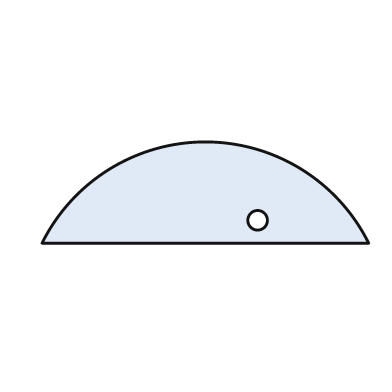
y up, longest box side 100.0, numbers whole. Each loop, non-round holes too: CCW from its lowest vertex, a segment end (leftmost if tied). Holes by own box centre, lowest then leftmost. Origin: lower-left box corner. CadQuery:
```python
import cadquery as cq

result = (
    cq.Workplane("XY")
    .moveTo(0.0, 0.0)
    .lineTo(100.0, 0.0)
    .threePointArc((50.0, 31.0), (0.0, 0.0))
    .close()
    .moveTo(66.0, 7.0)
    .circle(3.0)
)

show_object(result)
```